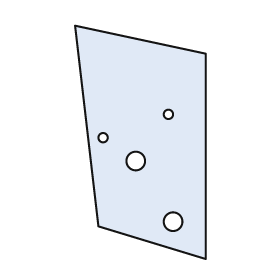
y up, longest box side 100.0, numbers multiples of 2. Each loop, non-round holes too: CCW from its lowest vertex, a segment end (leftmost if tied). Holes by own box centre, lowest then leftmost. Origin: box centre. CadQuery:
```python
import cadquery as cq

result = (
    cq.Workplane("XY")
    .moveTo(28.0, -50.0)
    .lineTo(28.0, 38.0)
    .lineTo(-28.0, 50.0)
    .lineTo(-18.0, -36.0)
    .close()
    .moveTo(14.0, -34.0)
    .circle(4.0)
    .moveTo(-2.0, -8.0)
    .circle(4.0)
    .moveTo(-16.0, 2.0)
    .circle(2.0)
    .moveTo(12.0, 12.0)
    .circle(2.0)
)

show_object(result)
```